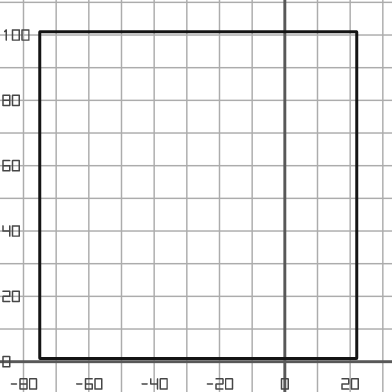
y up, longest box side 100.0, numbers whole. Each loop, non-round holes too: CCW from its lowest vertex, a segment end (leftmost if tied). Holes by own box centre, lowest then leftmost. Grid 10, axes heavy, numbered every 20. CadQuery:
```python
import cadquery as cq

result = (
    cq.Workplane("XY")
    .moveTo(-75.0, 1.0)
    .lineTo(22.0, 1.0)
    .lineTo(22.0, 101.0)
    .lineTo(-75.0, 101.0)
    .close()
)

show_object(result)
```